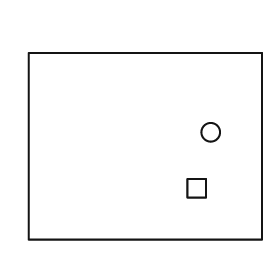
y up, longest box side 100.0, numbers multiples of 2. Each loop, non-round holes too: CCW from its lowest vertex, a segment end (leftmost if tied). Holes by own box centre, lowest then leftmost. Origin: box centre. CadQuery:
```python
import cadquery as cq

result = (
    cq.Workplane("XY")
    .moveTo(-50.0, -40.0)
    .lineTo(50.0, -40.0)
    .lineTo(50.0, 40.0)
    .lineTo(-50.0, 40.0)
    .close()
    .moveTo(18.0, -22.0)
    .lineTo(26.0, -22.0)
    .lineTo(26.0, -14.0)
    .lineTo(18.0, -14.0)
    .close()
    .moveTo(28.0, 6.0)
    .circle(4.0)
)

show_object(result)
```